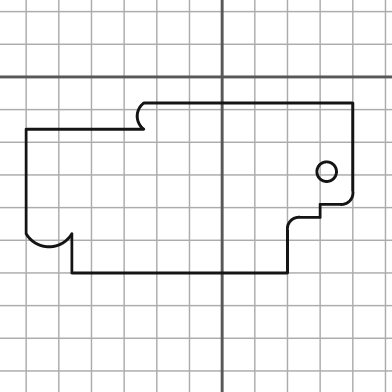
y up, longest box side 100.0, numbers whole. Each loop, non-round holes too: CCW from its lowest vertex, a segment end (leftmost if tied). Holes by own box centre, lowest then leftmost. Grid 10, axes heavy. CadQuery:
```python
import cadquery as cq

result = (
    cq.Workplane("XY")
    .moveTo(-46.0, -60.0)
    .lineTo(20.0, -60.0)
    .lineTo(20.0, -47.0)
    .threePointArc((21.0, -44.0), (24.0, -43.0))
    .lineTo(30.0, -43.0)
    .lineTo(30.0, -39.0)
    .lineTo(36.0, -39.0)
    .threePointArc((39.0, -38.0), (40.0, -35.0))
    .lineTo(40.0, -8.0)
    .lineTo(-24.0, -8.0)
    .threePointArc((-26.0, -12.0), (-24.0, -16.0))
    .lineTo(-60.0, -16.0)
    .lineTo(-60.0, -48.0)
    .threePointArc((-53.0, -52.0), (-46.0, -48.0))
    .close()
    .moveTo(32.0, -29.0)
    .circle(3.0)
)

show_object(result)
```